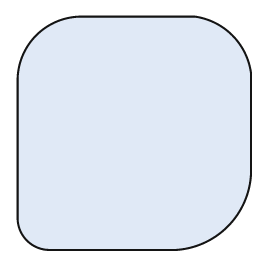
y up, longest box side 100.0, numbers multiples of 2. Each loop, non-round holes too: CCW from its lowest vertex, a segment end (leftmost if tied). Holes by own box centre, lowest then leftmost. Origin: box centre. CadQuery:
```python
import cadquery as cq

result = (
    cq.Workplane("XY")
    .moveTo(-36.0, -50.0)
    .lineTo(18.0, -50.0)
    .threePointArc((40.0, -40.0), (50.0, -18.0))
    .lineTo(50.0, 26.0)
    .threePointArc((42.0, 42.0), (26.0, 50.0))
    .lineTo(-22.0, 50.0)
    .threePointArc((-42.0, 42.0), (-50.0, 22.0))
    .lineTo(-50.0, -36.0)
    .threePointArc((-46.0, -46.0), (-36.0, -50.0))
    .close()
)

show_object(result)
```